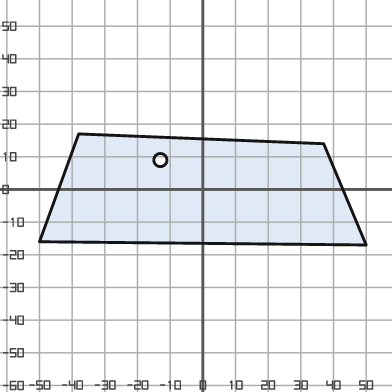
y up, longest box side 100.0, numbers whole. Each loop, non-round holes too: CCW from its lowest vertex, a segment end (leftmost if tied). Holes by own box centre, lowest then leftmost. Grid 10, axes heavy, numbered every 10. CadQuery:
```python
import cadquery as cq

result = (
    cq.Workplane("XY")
    .moveTo(50.0, -17.0)
    .lineTo(37.0, 14.0)
    .lineTo(-38.0, 17.0)
    .lineTo(-50.0, -16.0)
    .close()
    .moveTo(-13.0, 9.0)
    .circle(2.0)
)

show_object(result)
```